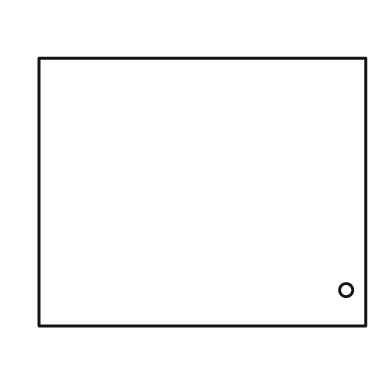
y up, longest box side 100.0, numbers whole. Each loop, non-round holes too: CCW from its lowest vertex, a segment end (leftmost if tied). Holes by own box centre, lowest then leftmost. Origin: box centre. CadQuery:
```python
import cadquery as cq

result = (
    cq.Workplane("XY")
    .moveTo(-50.0, -41.0)
    .lineTo(50.0, -41.0)
    .lineTo(50.0, 41.0)
    .lineTo(-50.0, 41.0)
    .close()
    .moveTo(44.0, -30.0)
    .circle(2.0)
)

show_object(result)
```